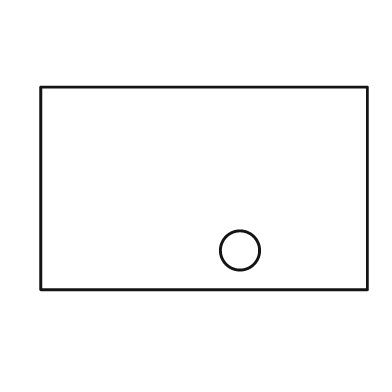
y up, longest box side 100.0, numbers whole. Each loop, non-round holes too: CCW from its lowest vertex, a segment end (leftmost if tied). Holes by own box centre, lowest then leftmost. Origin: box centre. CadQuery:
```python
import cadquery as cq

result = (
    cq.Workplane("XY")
    .moveTo(-50.0, -31.0)
    .lineTo(50.0, -31.0)
    .lineTo(50.0, 31.0)
    .lineTo(-50.0, 31.0)
    .close()
    .moveTo(11.0, -19.0)
    .circle(6.0)
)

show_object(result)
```